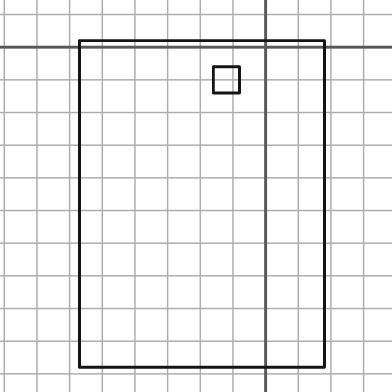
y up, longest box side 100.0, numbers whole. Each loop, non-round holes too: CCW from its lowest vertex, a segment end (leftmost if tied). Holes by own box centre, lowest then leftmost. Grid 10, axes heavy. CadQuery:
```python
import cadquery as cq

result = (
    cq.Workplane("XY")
    .moveTo(-57.0, -98.0)
    .lineTo(18.0, -98.0)
    .lineTo(18.0, 2.0)
    .lineTo(-57.0, 2.0)
    .close()
    .moveTo(-16.0, -14.0)
    .lineTo(-8.0, -14.0)
    .lineTo(-8.0, -6.0)
    .lineTo(-16.0, -6.0)
    .close()
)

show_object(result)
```